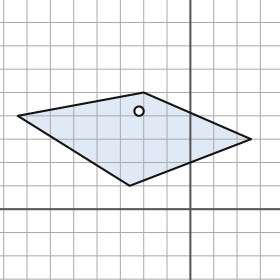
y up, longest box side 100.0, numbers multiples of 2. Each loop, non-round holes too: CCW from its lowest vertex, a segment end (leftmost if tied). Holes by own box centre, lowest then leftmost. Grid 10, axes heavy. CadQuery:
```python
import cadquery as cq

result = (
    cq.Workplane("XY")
    .moveTo(-26.0, 10.0)
    .lineTo(26.0, 30.0)
    .lineTo(-20.0, 50.0)
    .lineTo(-74.0, 40.0)
    .close()
    .moveTo(-22.0, 42.0)
    .circle(2.0)
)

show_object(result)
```